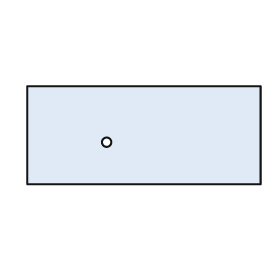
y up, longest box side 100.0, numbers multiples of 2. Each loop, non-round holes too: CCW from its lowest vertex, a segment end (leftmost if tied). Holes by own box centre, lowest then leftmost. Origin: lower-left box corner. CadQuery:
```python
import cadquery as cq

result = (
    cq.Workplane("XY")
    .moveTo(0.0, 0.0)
    .lineTo(100.0, 0.0)
    .lineTo(100.0, 42.0)
    .lineTo(0.0, 42.0)
    .close()
    .moveTo(34.0, 18.0)
    .circle(2.0)
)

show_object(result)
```